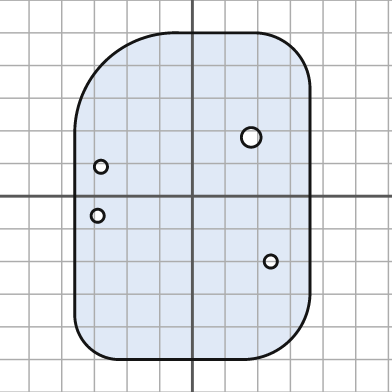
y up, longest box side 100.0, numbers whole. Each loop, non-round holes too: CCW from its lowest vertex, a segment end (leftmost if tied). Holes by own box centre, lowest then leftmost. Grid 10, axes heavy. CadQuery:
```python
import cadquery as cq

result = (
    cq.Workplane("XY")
    .moveTo(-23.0, -50.0)
    .lineTo(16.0, -50.0)
    .threePointArc((30.0, -44.0), (36.0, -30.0))
    .lineTo(36.0, 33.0)
    .threePointArc((31.0, 45.0), (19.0, 50.0))
    .lineTo(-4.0, 50.0)
    .threePointArc((-27.0, 41.0), (-36.0, 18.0))
    .lineTo(-36.0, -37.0)
    .threePointArc((-32.0, -46.0), (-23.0, -50.0))
    .close()
    .moveTo(24.0, -20.0)
    .circle(2.0)
    .moveTo(-29.0, -6.0)
    .circle(2.0)
    .moveTo(-28.0, 9.0)
    .circle(2.0)
    .moveTo(18.0, 18.0)
    .circle(3.0)
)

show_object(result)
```